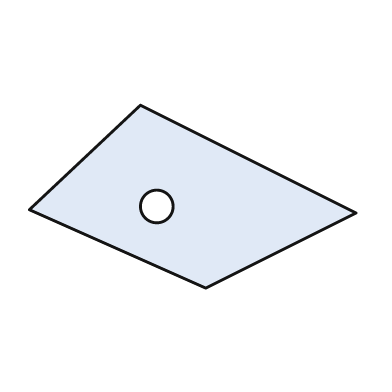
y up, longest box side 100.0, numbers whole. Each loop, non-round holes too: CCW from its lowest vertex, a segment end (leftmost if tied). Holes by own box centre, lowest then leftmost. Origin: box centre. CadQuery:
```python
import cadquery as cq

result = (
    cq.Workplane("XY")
    .moveTo(4.0, -28.0)
    .lineTo(50.0, -5.0)
    .lineTo(-16.0, 28.0)
    .lineTo(-50.0, -4.0)
    .close()
    .moveTo(-11.0, -3.0)
    .circle(5.0)
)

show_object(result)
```